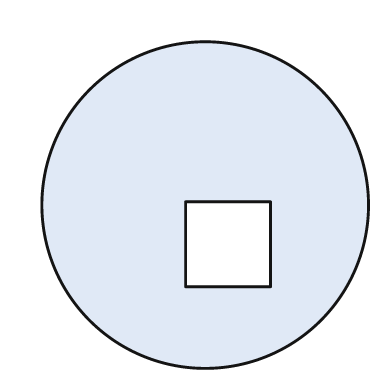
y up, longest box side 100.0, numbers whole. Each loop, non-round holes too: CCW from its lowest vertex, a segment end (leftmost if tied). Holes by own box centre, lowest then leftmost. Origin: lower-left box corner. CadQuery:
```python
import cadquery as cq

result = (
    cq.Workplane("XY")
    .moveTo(50.0, 50.0)
    .circle(50.0)
    .moveTo(44.0, 25.0)
    .lineTo(70.0, 25.0)
    .lineTo(70.0, 51.0)
    .lineTo(44.0, 51.0)
    .close()
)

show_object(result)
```